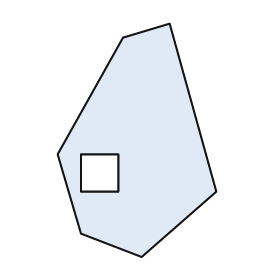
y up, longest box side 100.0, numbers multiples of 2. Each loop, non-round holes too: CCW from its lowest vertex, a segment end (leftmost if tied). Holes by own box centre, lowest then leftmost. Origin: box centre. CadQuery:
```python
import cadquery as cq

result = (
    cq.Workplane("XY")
    .moveTo(2.0, -50.0)
    .lineTo(34.0, -22.0)
    .lineTo(14.0, 50.0)
    .lineTo(-6.0, 44.0)
    .lineTo(-34.0, -6.0)
    .lineTo(-24.0, -40.0)
    .close()
    .moveTo(-24.0, -22.0)
    .lineTo(-8.0, -22.0)
    .lineTo(-8.0, -6.0)
    .lineTo(-24.0, -6.0)
    .close()
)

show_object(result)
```